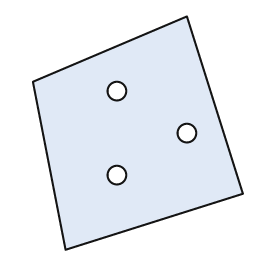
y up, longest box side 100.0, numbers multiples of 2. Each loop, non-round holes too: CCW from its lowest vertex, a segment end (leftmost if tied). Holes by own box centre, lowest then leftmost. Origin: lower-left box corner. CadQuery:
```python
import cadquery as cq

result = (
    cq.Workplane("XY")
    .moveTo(14.0, 0.0)
    .lineTo(90.0, 24.0)
    .lineTo(66.0, 100.0)
    .lineTo(0.0, 72.0)
    .close()
    .moveTo(36.0, 32.0)
    .circle(4.0)
    .moveTo(66.0, 50.0)
    .circle(4.0)
    .moveTo(36.0, 68.0)
    .circle(4.0)
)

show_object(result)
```